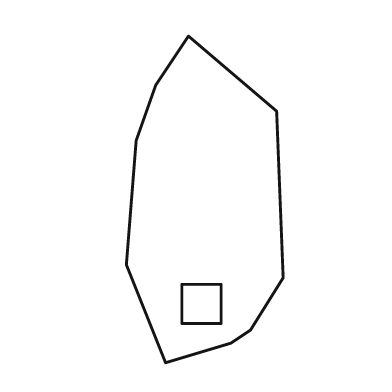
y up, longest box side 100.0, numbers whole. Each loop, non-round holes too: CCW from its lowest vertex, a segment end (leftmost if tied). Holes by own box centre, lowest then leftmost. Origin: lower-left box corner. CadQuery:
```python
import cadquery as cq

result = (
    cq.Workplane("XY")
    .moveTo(12.0, 0.0)
    .lineTo(32.0, 6.0)
    .lineTo(38.0, 10.0)
    .lineTo(48.0, 26.0)
    .lineTo(46.0, 77.0)
    .lineTo(19.0, 100.0)
    .lineTo(9.0, 85.0)
    .lineTo(3.0, 68.0)
    .lineTo(0.0, 30.0)
    .close()
    .moveTo(17.0, 12.0)
    .lineTo(29.0, 12.0)
    .lineTo(29.0, 24.0)
    .lineTo(17.0, 24.0)
    .close()
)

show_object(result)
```